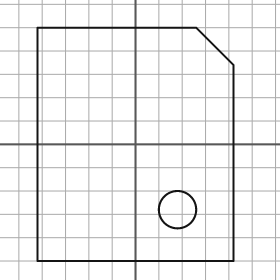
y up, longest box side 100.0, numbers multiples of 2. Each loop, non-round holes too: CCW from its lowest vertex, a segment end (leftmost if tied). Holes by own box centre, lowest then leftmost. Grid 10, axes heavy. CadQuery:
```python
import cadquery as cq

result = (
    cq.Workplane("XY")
    .moveTo(-42.0, -50.0)
    .lineTo(42.0, -50.0)
    .lineTo(42.0, 34.0)
    .lineTo(26.0, 50.0)
    .lineTo(-42.0, 50.0)
    .close()
    .moveTo(18.0, -28.0)
    .circle(8.0)
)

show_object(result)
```